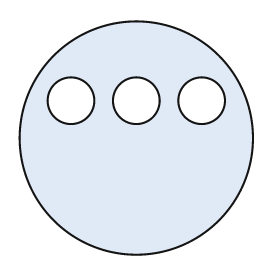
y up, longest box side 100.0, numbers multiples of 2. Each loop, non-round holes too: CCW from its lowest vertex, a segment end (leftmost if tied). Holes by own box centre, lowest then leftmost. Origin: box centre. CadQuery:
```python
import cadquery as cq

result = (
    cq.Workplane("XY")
    .moveTo(0.0, 0.0)
    .circle(50.0)
    .moveTo(-28.0, 16.0)
    .circle(10.0)
    .moveTo(0.0, 16.0)
    .circle(10.0)
    .moveTo(28.0, 16.0)
    .circle(10.0)
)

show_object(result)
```